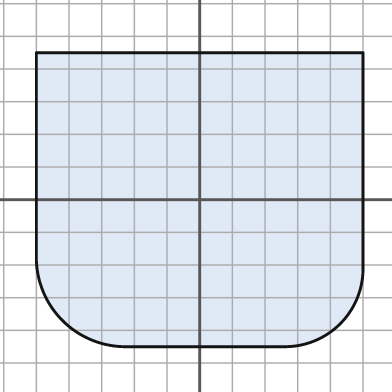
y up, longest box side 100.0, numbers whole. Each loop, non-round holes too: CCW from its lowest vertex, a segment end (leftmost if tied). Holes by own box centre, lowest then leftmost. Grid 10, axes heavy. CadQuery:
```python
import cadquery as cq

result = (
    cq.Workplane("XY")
    .moveTo(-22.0, -45.0)
    .lineTo(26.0, -45.0)
    .threePointArc((43.0, -38.0), (50.0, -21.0))
    .lineTo(50.0, 45.0)
    .lineTo(-50.0, 45.0)
    .lineTo(-50.0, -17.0)
    .threePointArc((-42.0, -37.0), (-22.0, -45.0))
    .close()
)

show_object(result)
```